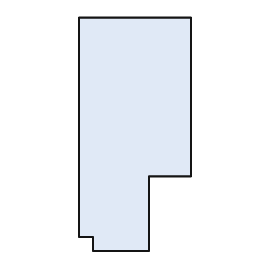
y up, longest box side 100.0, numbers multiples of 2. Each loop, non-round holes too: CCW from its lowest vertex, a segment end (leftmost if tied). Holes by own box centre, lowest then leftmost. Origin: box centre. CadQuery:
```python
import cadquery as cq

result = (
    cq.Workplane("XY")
    .moveTo(-18.0, -50.0)
    .lineTo(6.0, -50.0)
    .lineTo(6.0, -18.0)
    .lineTo(24.0, -18.0)
    .lineTo(24.0, 50.0)
    .lineTo(-24.0, 50.0)
    .lineTo(-24.0, -44.0)
    .lineTo(-18.0, -44.0)
    .close()
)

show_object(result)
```